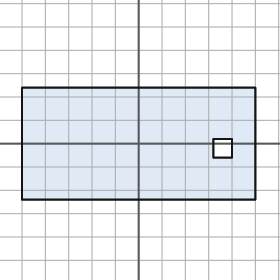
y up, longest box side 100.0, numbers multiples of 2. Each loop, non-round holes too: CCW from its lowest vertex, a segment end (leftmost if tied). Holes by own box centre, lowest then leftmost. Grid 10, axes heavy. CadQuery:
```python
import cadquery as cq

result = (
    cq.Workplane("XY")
    .moveTo(-50.0, -24.0)
    .lineTo(50.0, -24.0)
    .lineTo(50.0, 24.0)
    .lineTo(-50.0, 24.0)
    .close()
    .moveTo(32.0, -6.0)
    .lineTo(40.0, -6.0)
    .lineTo(40.0, 2.0)
    .lineTo(32.0, 2.0)
    .close()
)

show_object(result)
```